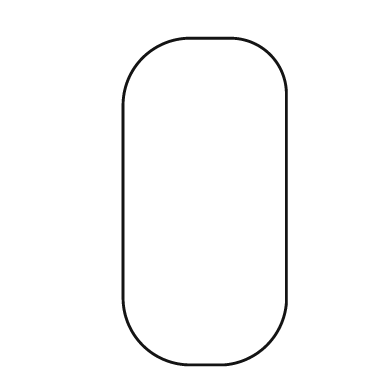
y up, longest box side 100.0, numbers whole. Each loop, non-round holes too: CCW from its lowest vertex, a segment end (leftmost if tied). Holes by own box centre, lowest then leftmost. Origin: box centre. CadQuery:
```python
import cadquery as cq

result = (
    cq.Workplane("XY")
    .moveTo(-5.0, -50.0)
    .lineTo(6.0, -50.0)
    .threePointArc((19.0, -44.0), (25.0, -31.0))
    .lineTo(25.0, 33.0)
    .threePointArc((20.0, 45.0), (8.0, 50.0))
    .lineTo(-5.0, 50.0)
    .threePointArc((-19.0, 44.0), (-25.0, 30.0))
    .lineTo(-25.0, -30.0)
    .threePointArc((-19.0, -44.0), (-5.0, -50.0))
    .close()
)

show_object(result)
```